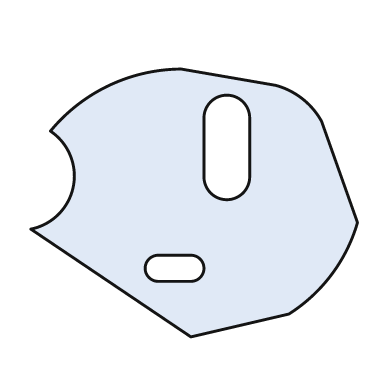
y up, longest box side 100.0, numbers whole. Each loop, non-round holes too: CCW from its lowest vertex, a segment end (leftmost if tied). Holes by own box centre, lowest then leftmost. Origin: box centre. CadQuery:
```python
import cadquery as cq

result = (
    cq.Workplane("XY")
    .moveTo(-1.0, -41.0)
    .lineTo(29.0, -34.0)
    .threePointArc((42.0, -22.0), (50.0, -6.0))
    .lineTo(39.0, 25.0)
    .threePointArc((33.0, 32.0), (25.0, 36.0))
    .lineTo(-4.0, 41.0)
    .threePointArc((-26.0, 36.0), (-44.0, 22.0))
    .threePointArc((-37.0, 5.0), (-50.0, -8.0))
    .close()
    .moveTo(-11.0, -24.0)
    .lineTo(-1.0, -24.0)
    .threePointArc((3.0, -20.0), (-1.0, -16.0))
    .lineTo(-11.0, -16.0)
    .threePointArc((-15.0, -20.0), (-11.0, -24.0))
    .close()
    .moveTo(3.0, 8.0)
    .threePointArc((10.0, 1.0), (17.0, 8.0))
    .lineTo(17.0, 26.0)
    .threePointArc((10.0, 33.0), (3.0, 26.0))
    .close()
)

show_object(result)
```